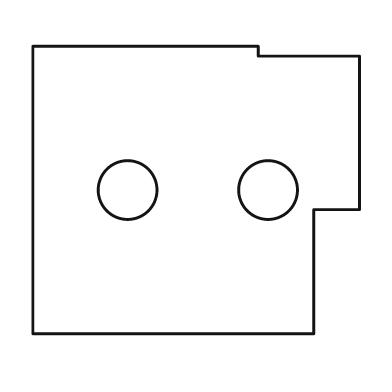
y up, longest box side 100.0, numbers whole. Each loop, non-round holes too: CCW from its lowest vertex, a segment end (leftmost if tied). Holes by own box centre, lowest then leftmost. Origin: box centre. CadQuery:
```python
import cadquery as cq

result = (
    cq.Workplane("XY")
    .moveTo(-50.0, -44.0)
    .lineTo(36.0, -44.0)
    .lineTo(36.0, -6.0)
    .lineTo(50.0, -6.0)
    .lineTo(50.0, 41.0)
    .lineTo(19.0, 41.0)
    .lineTo(19.0, 44.0)
    .lineTo(-50.0, 44.0)
    .close()
    .moveTo(-21.0, 0.0)
    .circle(9.0)
    .moveTo(22.0, 0.0)
    .circle(9.0)
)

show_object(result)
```